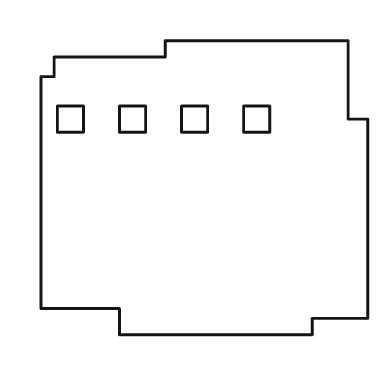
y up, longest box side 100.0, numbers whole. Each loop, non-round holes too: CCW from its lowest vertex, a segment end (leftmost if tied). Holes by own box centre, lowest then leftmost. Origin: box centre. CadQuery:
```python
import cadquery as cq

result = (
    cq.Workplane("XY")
    .moveTo(-26.0, -45.0)
    .lineTo(33.0, -45.0)
    .lineTo(33.0, -40.0)
    .lineTo(50.0, -40.0)
    .lineTo(50.0, 21.0)
    .lineTo(44.0, 21.0)
    .lineTo(44.0, 45.0)
    .lineTo(-12.0, 45.0)
    .lineTo(-12.0, 40.0)
    .lineTo(-46.0, 40.0)
    .lineTo(-46.0, 34.0)
    .lineTo(-50.0, 34.0)
    .lineTo(-50.0, -37.0)
    .lineTo(-26.0, -37.0)
    .close()
    .moveTo(-45.0, 17.0)
    .lineTo(-37.0, 17.0)
    .lineTo(-37.0, 25.0)
    .lineTo(-45.0, 25.0)
    .close()
    .moveTo(-26.0, 17.0)
    .lineTo(-18.0, 17.0)
    .lineTo(-18.0, 25.0)
    .lineTo(-26.0, 25.0)
    .close()
    .moveTo(-7.0, 17.0)
    .lineTo(1.0, 17.0)
    .lineTo(1.0, 25.0)
    .lineTo(-7.0, 25.0)
    .close()
    .moveTo(12.0, 17.0)
    .lineTo(20.0, 17.0)
    .lineTo(20.0, 25.0)
    .lineTo(12.0, 25.0)
    .close()
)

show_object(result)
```